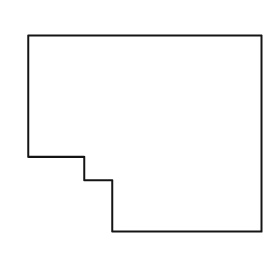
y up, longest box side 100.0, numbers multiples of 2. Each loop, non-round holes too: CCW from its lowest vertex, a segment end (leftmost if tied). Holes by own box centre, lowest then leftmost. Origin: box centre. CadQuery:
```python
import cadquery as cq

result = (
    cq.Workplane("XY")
    .moveTo(-14.0, -42.0)
    .lineTo(50.0, -42.0)
    .lineTo(50.0, 42.0)
    .lineTo(-50.0, 42.0)
    .lineTo(-50.0, -10.0)
    .lineTo(-26.0, -10.0)
    .lineTo(-26.0, -20.0)
    .lineTo(-14.0, -20.0)
    .close()
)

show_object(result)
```